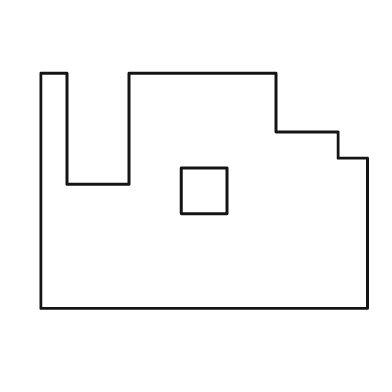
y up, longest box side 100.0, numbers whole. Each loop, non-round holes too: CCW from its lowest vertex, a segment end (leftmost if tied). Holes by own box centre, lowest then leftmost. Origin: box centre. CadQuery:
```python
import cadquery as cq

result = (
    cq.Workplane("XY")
    .moveTo(-50.0, -36.0)
    .lineTo(50.0, -36.0)
    .lineTo(50.0, 10.0)
    .lineTo(41.0, 10.0)
    .lineTo(41.0, 18.0)
    .lineTo(22.0, 18.0)
    .lineTo(22.0, 36.0)
    .lineTo(-23.0, 36.0)
    .lineTo(-23.0, 2.0)
    .lineTo(-42.0, 2.0)
    .lineTo(-42.0, 36.0)
    .lineTo(-50.0, 36.0)
    .close()
    .moveTo(-7.0, -7.0)
    .lineTo(7.0, -7.0)
    .lineTo(7.0, 7.0)
    .lineTo(-7.0, 7.0)
    .close()
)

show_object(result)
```